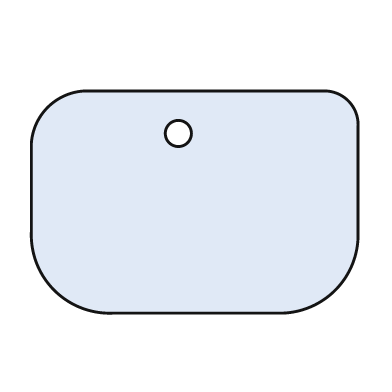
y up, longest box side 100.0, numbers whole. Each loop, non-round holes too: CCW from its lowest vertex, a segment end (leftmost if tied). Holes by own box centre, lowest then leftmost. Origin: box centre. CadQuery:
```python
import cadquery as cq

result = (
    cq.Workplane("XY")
    .moveTo(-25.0, -34.0)
    .lineTo(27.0, -34.0)
    .threePointArc((43.0, -27.0), (50.0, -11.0))
    .lineTo(50.0, 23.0)
    .threePointArc((47.0, 31.0), (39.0, 34.0))
    .lineTo(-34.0, 34.0)
    .threePointArc((-45.0, 29.0), (-50.0, 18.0))
    .lineTo(-50.0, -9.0)
    .threePointArc((-43.0, -27.0), (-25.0, -34.0))
    .close()
    .moveTo(-5.0, 21.0)
    .circle(4.0)
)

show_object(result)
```